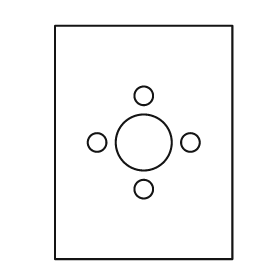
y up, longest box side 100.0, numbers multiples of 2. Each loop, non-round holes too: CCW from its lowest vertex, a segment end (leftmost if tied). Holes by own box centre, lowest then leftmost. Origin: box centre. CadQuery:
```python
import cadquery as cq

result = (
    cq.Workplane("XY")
    .moveTo(-38.0, -50.0)
    .lineTo(38.0, -50.0)
    .lineTo(38.0, 50.0)
    .lineTo(-38.0, 50.0)
    .close()
    .moveTo(0.0, -20.0)
    .circle(4.0)
    .moveTo(-20.0, 0.0)
    .circle(4.0)
    .moveTo(0.0, 0.0)
    .circle(12.0)
    .moveTo(20.0, 0.0)
    .circle(4.0)
    .moveTo(0.0, 20.0)
    .circle(4.0)
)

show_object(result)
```